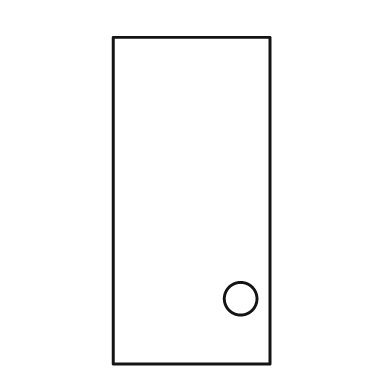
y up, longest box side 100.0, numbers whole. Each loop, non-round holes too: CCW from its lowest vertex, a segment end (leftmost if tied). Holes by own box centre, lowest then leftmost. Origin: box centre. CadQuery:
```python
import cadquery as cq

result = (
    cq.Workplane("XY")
    .moveTo(-24.0, -50.0)
    .lineTo(24.0, -50.0)
    .lineTo(24.0, 50.0)
    .lineTo(-24.0, 50.0)
    .close()
    .moveTo(15.0, -30.0)
    .circle(5.0)
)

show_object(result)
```